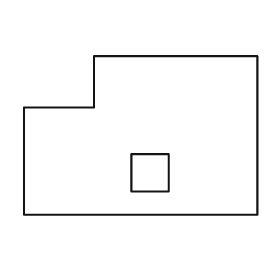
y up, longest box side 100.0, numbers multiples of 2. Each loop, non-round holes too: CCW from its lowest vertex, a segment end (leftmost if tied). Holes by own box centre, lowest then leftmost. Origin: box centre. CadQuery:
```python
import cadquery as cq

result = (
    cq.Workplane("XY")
    .moveTo(-50.0, -34.0)
    .lineTo(50.0, -34.0)
    .lineTo(50.0, 34.0)
    .lineTo(-20.0, 34.0)
    .lineTo(-20.0, 12.0)
    .lineTo(-50.0, 12.0)
    .close()
    .moveTo(-4.0, -24.0)
    .lineTo(12.0, -24.0)
    .lineTo(12.0, -8.0)
    .lineTo(-4.0, -8.0)
    .close()
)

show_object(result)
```